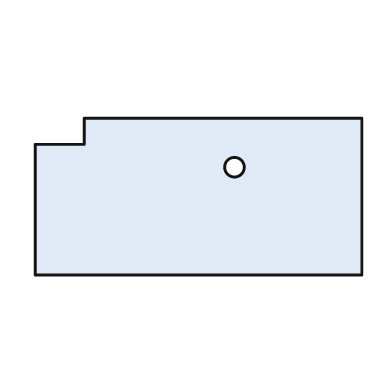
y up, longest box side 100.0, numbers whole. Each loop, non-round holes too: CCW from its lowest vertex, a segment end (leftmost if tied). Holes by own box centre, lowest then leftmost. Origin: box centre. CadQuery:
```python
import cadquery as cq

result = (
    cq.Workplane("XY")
    .moveTo(-50.0, -24.0)
    .lineTo(50.0, -24.0)
    .lineTo(50.0, 24.0)
    .lineTo(-35.0, 24.0)
    .lineTo(-35.0, 16.0)
    .lineTo(-50.0, 16.0)
    .close()
    .moveTo(11.0, 9.0)
    .circle(3.0)
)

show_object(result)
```